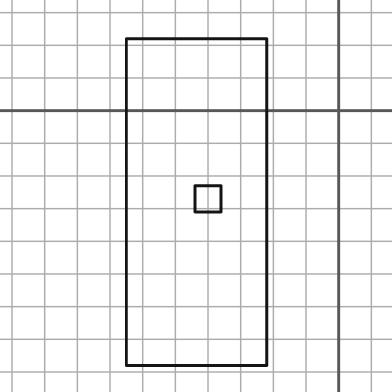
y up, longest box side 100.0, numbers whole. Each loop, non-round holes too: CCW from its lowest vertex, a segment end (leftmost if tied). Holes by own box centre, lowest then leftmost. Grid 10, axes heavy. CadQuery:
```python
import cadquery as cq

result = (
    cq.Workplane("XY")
    .moveTo(-65.0, -78.0)
    .lineTo(-22.0, -78.0)
    .lineTo(-22.0, 22.0)
    .lineTo(-65.0, 22.0)
    .close()
    .moveTo(-44.0, -31.0)
    .lineTo(-36.0, -31.0)
    .lineTo(-36.0, -23.0)
    .lineTo(-44.0, -23.0)
    .close()
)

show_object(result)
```